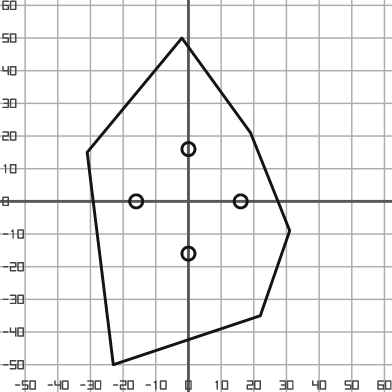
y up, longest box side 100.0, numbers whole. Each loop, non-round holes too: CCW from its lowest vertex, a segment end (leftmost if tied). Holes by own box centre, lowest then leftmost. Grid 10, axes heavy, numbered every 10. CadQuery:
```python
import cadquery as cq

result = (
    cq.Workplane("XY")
    .moveTo(-23.0, -50.0)
    .lineTo(22.0, -35.0)
    .lineTo(31.0, -9.0)
    .lineTo(19.0, 21.0)
    .lineTo(-2.0, 50.0)
    .lineTo(-31.0, 15.0)
    .close()
    .moveTo(0.0, -16.0)
    .circle(2.0)
    .moveTo(-16.0, 0.0)
    .circle(2.0)
    .moveTo(16.0, 0.0)
    .circle(2.0)
    .moveTo(0.0, 16.0)
    .circle(2.0)
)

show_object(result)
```